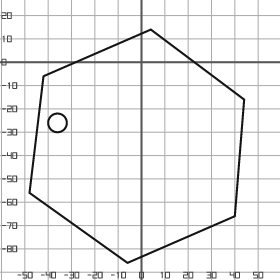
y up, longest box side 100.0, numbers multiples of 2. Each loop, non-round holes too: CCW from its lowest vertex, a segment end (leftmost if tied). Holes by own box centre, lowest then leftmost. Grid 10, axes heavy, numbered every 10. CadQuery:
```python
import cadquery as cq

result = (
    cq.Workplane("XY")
    .moveTo(-6.0, -86.0)
    .lineTo(40.0, -66.0)
    .lineTo(44.0, -16.0)
    .lineTo(4.0, 14.0)
    .lineTo(-42.0, -6.0)
    .lineTo(-48.0, -56.0)
    .close()
    .moveTo(-36.0, -26.0)
    .circle(4.0)
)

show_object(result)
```